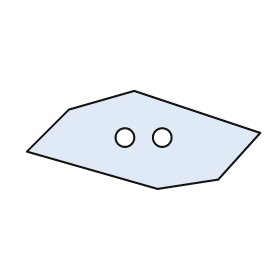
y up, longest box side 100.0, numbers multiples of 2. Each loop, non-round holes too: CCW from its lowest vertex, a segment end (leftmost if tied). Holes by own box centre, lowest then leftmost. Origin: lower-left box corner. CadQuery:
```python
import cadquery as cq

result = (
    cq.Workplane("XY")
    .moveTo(56.0, 0.0)
    .lineTo(82.0, 4.0)
    .lineTo(100.0, 24.0)
    .lineTo(46.0, 42.0)
    .lineTo(18.0, 34.0)
    .lineTo(0.0, 16.0)
    .close()
    .moveTo(42.0, 22.0)
    .circle(4.0)
    .moveTo(58.0, 22.0)
    .circle(4.0)
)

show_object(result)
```